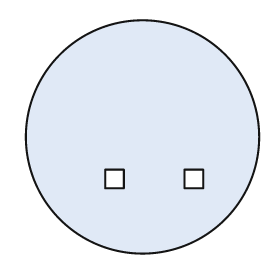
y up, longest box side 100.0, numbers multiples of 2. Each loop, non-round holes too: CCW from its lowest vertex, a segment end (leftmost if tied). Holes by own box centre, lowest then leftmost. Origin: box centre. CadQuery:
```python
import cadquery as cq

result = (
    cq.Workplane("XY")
    .moveTo(0.0, 0.0)
    .circle(50.0)
    .moveTo(-16.0, -22.0)
    .lineTo(-8.0, -22.0)
    .lineTo(-8.0, -14.0)
    .lineTo(-16.0, -14.0)
    .close()
    .moveTo(18.0, -22.0)
    .lineTo(26.0, -22.0)
    .lineTo(26.0, -14.0)
    .lineTo(18.0, -14.0)
    .close()
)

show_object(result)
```